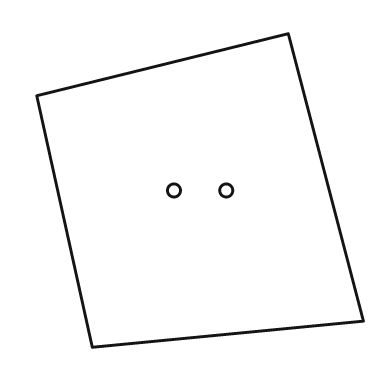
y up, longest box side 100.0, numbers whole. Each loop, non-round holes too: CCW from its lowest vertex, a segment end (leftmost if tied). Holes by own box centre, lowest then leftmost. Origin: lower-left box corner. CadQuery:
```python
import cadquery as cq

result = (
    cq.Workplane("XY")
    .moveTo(17.0, 0.0)
    .lineTo(100.0, 8.0)
    .lineTo(77.0, 96.0)
    .lineTo(0.0, 77.0)
    .close()
    .moveTo(42.0, 48.0)
    .circle(2.0)
    .moveTo(58.0, 48.0)
    .circle(2.0)
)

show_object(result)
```